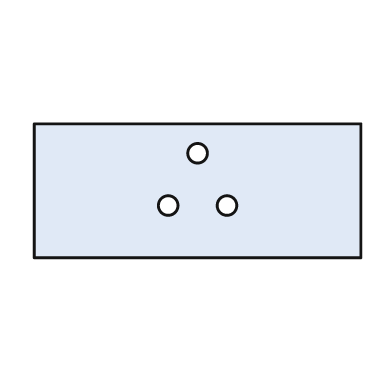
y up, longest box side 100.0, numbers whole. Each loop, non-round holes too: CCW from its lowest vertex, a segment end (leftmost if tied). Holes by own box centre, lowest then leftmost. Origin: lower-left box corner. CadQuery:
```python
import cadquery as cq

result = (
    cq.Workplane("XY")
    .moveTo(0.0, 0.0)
    .lineTo(100.0, 0.0)
    .lineTo(100.0, 41.0)
    .lineTo(0.0, 41.0)
    .close()
    .moveTo(41.0, 16.0)
    .circle(3.0)
    .moveTo(59.0, 16.0)
    .circle(3.0)
    .moveTo(50.0, 32.0)
    .circle(3.0)
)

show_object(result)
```